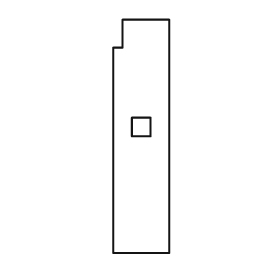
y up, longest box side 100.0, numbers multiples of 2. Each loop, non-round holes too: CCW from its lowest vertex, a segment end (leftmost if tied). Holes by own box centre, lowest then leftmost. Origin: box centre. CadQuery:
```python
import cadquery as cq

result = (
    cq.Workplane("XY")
    .moveTo(-12.0, -50.0)
    .lineTo(12.0, -50.0)
    .lineTo(12.0, 50.0)
    .lineTo(-8.0, 50.0)
    .lineTo(-8.0, 38.0)
    .lineTo(-12.0, 38.0)
    .close()
    .moveTo(-4.0, 0.0)
    .lineTo(4.0, 0.0)
    .lineTo(4.0, 8.0)
    .lineTo(-4.0, 8.0)
    .close()
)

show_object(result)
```